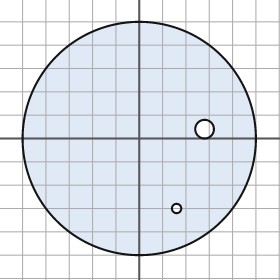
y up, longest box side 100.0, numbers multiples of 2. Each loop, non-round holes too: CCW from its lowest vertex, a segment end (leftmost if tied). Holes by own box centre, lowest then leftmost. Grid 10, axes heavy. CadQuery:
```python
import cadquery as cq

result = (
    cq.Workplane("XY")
    .moveTo(0.0, 0.0)
    .circle(50.0)
    .moveTo(16.0, -30.0)
    .circle(2.0)
    .moveTo(28.0, 4.0)
    .circle(4.0)
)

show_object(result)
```